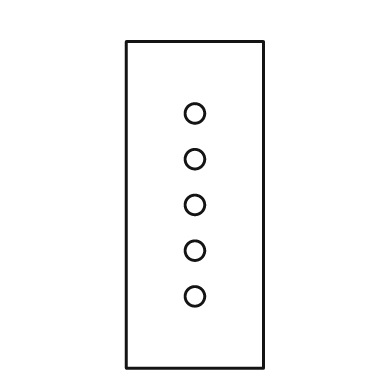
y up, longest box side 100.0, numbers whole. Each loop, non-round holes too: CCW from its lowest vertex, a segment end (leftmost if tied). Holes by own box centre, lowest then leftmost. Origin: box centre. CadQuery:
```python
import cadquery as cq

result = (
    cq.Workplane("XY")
    .moveTo(-21.0, -50.0)
    .lineTo(21.0, -50.0)
    .lineTo(21.0, 50.0)
    .lineTo(-21.0, 50.0)
    .close()
    .moveTo(0.0, -28.0)
    .circle(3.0)
    .moveTo(0.0, -14.0)
    .circle(3.0)
    .moveTo(0.0, 0.0)
    .circle(3.0)
    .moveTo(0.0, 14.0)
    .circle(3.0)
    .moveTo(0.0, 28.0)
    .circle(3.0)
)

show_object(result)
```